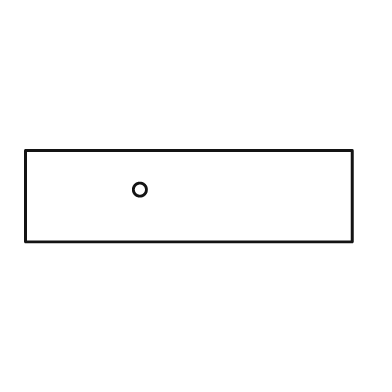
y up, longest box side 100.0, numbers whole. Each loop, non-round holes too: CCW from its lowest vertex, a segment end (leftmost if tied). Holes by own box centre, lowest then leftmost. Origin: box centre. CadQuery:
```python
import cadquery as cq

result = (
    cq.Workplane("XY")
    .moveTo(-50.0, -14.0)
    .lineTo(50.0, -14.0)
    .lineTo(50.0, 14.0)
    .lineTo(-50.0, 14.0)
    .close()
    .moveTo(-15.0, 2.0)
    .circle(2.0)
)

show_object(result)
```